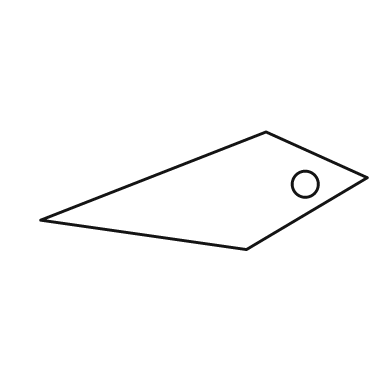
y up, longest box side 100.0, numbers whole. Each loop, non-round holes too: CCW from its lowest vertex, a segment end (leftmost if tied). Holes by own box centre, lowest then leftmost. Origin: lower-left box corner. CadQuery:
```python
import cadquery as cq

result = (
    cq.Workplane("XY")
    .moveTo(63.0, 0.0)
    .lineTo(100.0, 22.0)
    .lineTo(69.0, 36.0)
    .lineTo(0.0, 9.0)
    .close()
    .moveTo(81.0, 20.0)
    .circle(4.0)
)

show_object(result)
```